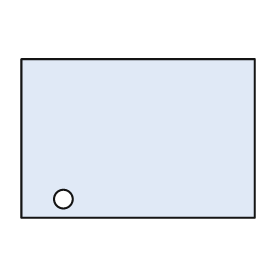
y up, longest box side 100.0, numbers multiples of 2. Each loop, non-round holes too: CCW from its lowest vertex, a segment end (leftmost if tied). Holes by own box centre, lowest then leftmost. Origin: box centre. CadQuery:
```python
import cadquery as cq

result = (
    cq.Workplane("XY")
    .moveTo(-50.0, -34.0)
    .lineTo(50.0, -34.0)
    .lineTo(50.0, 34.0)
    .lineTo(-50.0, 34.0)
    .close()
    .moveTo(-32.0, -26.0)
    .circle(4.0)
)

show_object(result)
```